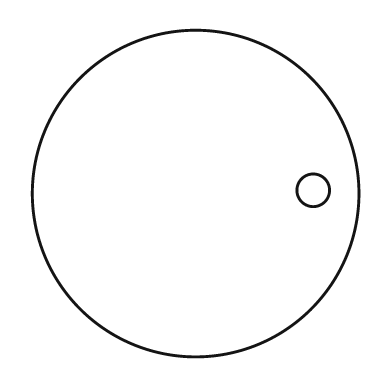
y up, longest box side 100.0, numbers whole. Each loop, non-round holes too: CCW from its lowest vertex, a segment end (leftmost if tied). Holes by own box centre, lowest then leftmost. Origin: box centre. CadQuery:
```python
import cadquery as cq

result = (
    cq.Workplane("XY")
    .moveTo(0.0, 0.0)
    .circle(50.0)
    .moveTo(36.0, 1.0)
    .circle(5.0)
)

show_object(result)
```